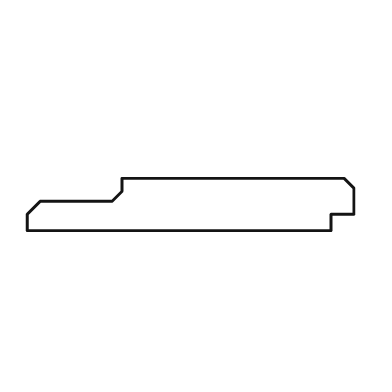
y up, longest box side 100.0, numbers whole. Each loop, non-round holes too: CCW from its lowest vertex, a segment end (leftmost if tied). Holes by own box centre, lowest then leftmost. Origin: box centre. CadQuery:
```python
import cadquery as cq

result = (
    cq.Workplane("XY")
    .moveTo(-50.0, -8.0)
    .lineTo(43.0, -8.0)
    .lineTo(43.0, -3.0)
    .lineTo(50.0, -3.0)
    .lineTo(50.0, 5.0)
    .lineTo(47.0, 8.0)
    .lineTo(-21.0, 8.0)
    .lineTo(-21.0, 4.0)
    .lineTo(-24.0, 1.0)
    .lineTo(-46.0, 1.0)
    .lineTo(-50.0, -3.0)
    .close()
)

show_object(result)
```